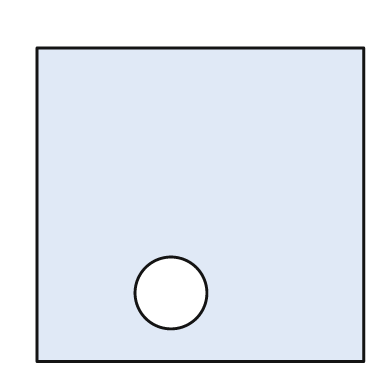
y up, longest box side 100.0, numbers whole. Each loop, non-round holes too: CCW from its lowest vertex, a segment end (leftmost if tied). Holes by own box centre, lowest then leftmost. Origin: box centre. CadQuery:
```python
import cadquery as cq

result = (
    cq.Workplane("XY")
    .moveTo(-50.0, -48.0)
    .lineTo(50.0, -48.0)
    .lineTo(50.0, 48.0)
    .lineTo(-50.0, 48.0)
    .close()
    .moveTo(-9.0, -27.0)
    .circle(11.0)
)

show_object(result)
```